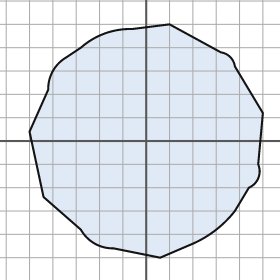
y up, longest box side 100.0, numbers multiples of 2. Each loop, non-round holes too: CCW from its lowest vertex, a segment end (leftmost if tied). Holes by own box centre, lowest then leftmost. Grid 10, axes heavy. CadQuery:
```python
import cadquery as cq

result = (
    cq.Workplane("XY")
    .moveTo(6.0, -50.0)
    .lineTo(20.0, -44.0)
    .threePointArc((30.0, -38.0), (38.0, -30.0))
    .lineTo(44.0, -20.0)
    .threePointArc((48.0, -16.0), (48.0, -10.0))
    .lineTo(50.0, 12.0)
    .lineTo(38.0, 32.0)
    .threePointArc((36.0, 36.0), (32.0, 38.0))
    .lineTo(10.0, 50.0)
    .lineTo(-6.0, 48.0)
    .threePointArc((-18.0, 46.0), (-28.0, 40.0))
    .lineTo(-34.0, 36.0)
    .threePointArc((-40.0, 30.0), (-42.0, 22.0))
    .lineTo(-50.0, 4.0)
    .lineTo(-44.0, -24.0)
    .lineTo(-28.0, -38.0)
    .threePointArc((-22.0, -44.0), (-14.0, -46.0))
    .close()
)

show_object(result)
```